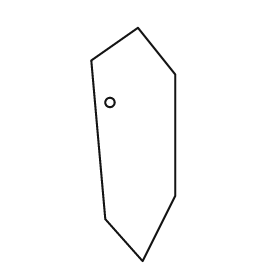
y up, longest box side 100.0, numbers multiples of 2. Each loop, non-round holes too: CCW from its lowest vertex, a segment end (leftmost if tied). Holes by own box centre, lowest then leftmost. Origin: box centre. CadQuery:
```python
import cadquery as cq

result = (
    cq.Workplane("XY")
    .moveTo(4.0, -50.0)
    .lineTo(18.0, -22.0)
    .lineTo(18.0, 30.0)
    .lineTo(2.0, 50.0)
    .lineTo(-18.0, 36.0)
    .lineTo(-12.0, -32.0)
    .close()
    .moveTo(-10.0, 18.0)
    .circle(2.0)
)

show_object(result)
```